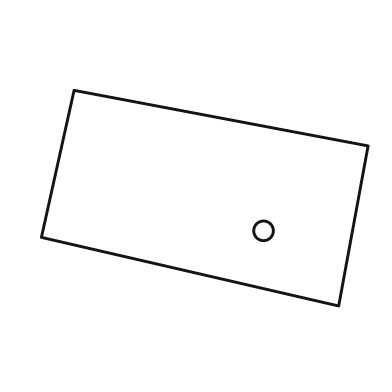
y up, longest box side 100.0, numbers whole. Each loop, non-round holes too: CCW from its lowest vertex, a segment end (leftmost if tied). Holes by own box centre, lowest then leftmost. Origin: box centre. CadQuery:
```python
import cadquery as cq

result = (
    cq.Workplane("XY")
    .moveTo(41.0, -33.0)
    .lineTo(50.0, 16.0)
    .lineTo(-40.0, 33.0)
    .lineTo(-50.0, -12.0)
    .close()
    .moveTo(18.0, -10.0)
    .circle(3.0)
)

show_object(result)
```